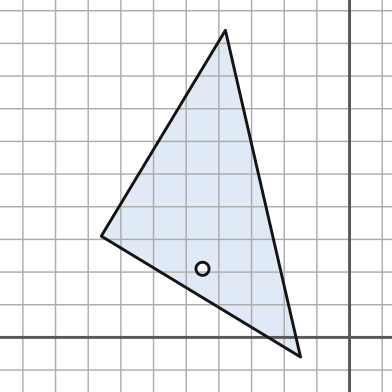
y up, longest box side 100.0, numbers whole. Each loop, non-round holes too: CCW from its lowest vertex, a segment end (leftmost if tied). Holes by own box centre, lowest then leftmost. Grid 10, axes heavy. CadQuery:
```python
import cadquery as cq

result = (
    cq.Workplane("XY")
    .moveTo(-15.0, -6.0)
    .lineTo(-38.0, 94.0)
    .lineTo(-76.0, 31.0)
    .close()
    .moveTo(-45.0, 21.0)
    .circle(2.0)
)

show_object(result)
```